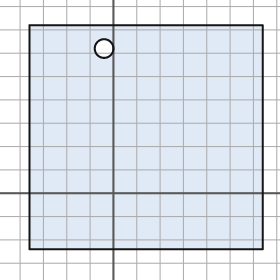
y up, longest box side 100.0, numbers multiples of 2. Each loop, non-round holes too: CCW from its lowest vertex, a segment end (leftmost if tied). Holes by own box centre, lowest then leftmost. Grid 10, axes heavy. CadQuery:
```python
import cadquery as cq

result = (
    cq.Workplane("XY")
    .moveTo(-36.0, -24.0)
    .lineTo(64.0, -24.0)
    .lineTo(64.0, 72.0)
    .lineTo(-36.0, 72.0)
    .close()
    .moveTo(-4.0, 62.0)
    .circle(4.0)
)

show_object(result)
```